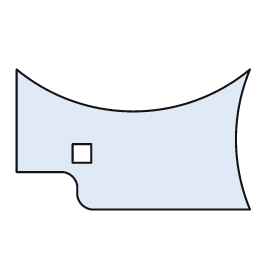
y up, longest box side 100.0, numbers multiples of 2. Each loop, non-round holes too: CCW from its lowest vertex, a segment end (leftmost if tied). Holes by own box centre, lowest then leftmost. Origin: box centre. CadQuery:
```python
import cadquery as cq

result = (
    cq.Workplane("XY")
    .moveTo(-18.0, -30.0)
    .lineTo(50.0, -30.0)
    .threePointArc((44.0, 0.0), (50.0, 30.0))
    .threePointArc((0.0, 12.0), (-50.0, 30.0))
    .lineTo(-50.0, -14.0)
    .lineTo(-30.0, -14.0)
    .threePointArc((-26.0, -16.0), (-24.0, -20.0))
    .lineTo(-24.0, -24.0)
    .threePointArc((-22.0, -28.0), (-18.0, -30.0))
    .close()
    .moveTo(-26.0, -10.0)
    .lineTo(-18.0, -10.0)
    .lineTo(-18.0, -2.0)
    .lineTo(-26.0, -2.0)
    .close()
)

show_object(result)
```